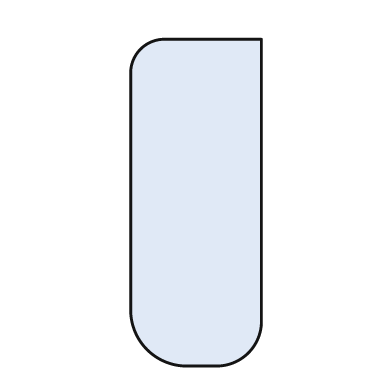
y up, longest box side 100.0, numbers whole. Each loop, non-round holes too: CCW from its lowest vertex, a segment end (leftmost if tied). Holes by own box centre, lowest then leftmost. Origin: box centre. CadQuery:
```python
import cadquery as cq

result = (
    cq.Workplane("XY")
    .moveTo(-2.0, -50.0)
    .lineTo(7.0, -50.0)
    .threePointArc((16.0, -46.0), (20.0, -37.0))
    .lineTo(20.0, 50.0)
    .lineTo(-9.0, 50.0)
    .threePointArc((-17.0, 47.0), (-20.0, 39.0))
    .lineTo(-20.0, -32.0)
    .threePointArc((-15.0, -45.0), (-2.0, -50.0))
    .close()
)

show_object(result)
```